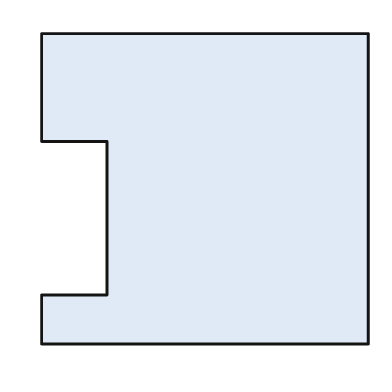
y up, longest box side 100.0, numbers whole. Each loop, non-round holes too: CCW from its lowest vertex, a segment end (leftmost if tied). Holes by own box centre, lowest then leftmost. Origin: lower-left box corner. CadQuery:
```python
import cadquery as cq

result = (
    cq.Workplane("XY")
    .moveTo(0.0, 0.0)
    .lineTo(100.0, 0.0)
    .lineTo(100.0, 95.0)
    .lineTo(0.0, 95.0)
    .lineTo(0.0, 62.0)
    .lineTo(20.0, 62.0)
    .lineTo(20.0, 15.0)
    .lineTo(0.0, 15.0)
    .close()
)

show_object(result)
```